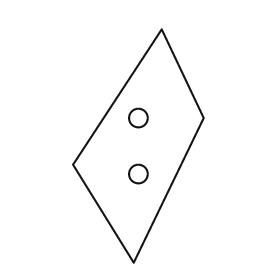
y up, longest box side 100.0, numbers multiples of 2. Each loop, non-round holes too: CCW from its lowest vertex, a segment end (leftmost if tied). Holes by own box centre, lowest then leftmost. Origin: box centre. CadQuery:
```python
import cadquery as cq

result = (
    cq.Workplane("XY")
    .moveTo(-2.0, -50.0)
    .lineTo(28.0, 12.0)
    .lineTo(10.0, 50.0)
    .lineTo(-28.0, -8.0)
    .close()
    .moveTo(0.0, -12.0)
    .circle(4.0)
    .moveTo(0.0, 12.0)
    .circle(4.0)
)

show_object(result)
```